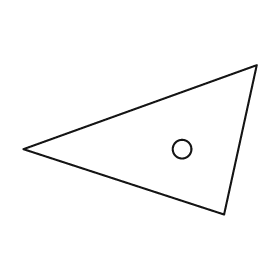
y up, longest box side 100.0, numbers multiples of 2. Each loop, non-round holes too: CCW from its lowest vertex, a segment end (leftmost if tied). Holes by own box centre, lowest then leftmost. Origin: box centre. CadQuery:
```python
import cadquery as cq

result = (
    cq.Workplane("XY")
    .moveTo(36.0, -32.0)
    .lineTo(50.0, 32.0)
    .lineTo(-50.0, -4.0)
    .close()
    .moveTo(18.0, -4.0)
    .circle(4.0)
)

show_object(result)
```